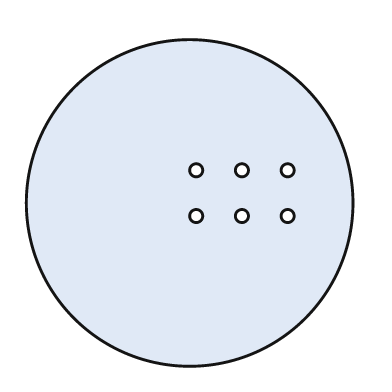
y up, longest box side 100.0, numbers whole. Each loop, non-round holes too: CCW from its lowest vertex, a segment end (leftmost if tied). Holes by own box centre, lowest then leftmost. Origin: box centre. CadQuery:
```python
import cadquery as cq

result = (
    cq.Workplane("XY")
    .moveTo(0.0, 0.0)
    .circle(50.0)
    .moveTo(2.0, -4.0)
    .circle(2.0)
    .moveTo(16.0, -4.0)
    .circle(2.0)
    .moveTo(30.0, -4.0)
    .circle(2.0)
    .moveTo(2.0, 10.0)
    .circle(2.0)
    .moveTo(16.0, 10.0)
    .circle(2.0)
    .moveTo(30.0, 10.0)
    .circle(2.0)
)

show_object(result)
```